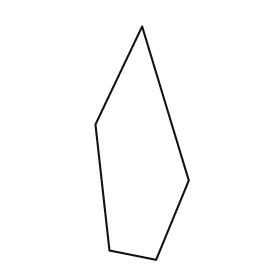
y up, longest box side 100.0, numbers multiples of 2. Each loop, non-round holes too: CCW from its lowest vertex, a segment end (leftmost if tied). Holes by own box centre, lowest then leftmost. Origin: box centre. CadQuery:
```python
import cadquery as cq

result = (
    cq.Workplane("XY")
    .moveTo(6.0, -50.0)
    .lineTo(20.0, -16.0)
    .lineTo(0.0, 50.0)
    .lineTo(-20.0, 8.0)
    .lineTo(-14.0, -46.0)
    .close()
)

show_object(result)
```